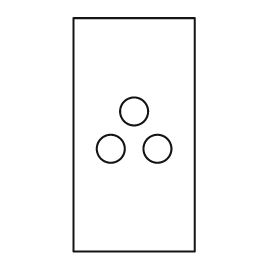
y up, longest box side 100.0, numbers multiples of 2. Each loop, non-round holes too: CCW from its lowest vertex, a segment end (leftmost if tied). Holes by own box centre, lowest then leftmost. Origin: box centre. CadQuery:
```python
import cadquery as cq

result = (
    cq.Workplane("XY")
    .moveTo(-26.0, -50.0)
    .lineTo(26.0, -50.0)
    .lineTo(26.0, 50.0)
    .lineTo(-26.0, 50.0)
    .close()
    .moveTo(-10.0, -6.0)
    .circle(6.0)
    .moveTo(10.0, -6.0)
    .circle(6.0)
    .moveTo(0.0, 10.0)
    .circle(6.0)
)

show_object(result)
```